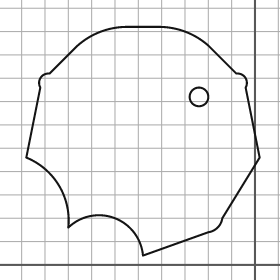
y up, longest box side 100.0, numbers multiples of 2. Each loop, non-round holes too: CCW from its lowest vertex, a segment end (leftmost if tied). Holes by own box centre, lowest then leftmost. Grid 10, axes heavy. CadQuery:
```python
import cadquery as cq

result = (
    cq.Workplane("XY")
    .moveTo(-48.0, 4.0)
    .lineTo(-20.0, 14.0)
    .threePointArc((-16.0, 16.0), (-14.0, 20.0))
    .lineTo(2.0, 46.0)
    .lineTo(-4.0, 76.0)
    .threePointArc((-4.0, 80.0), (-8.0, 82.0))
    .lineTo(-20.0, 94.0)
    .threePointArc((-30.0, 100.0), (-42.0, 102.0))
    .lineTo(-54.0, 102.0)
    .threePointArc((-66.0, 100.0), (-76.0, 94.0))
    .lineTo(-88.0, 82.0)
    .threePointArc((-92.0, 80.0), (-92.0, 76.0))
    .lineTo(-98.0, 46.0)
    .threePointArc((-84.0, 34.0), (-80.0, 16.0))
    .threePointArc((-60.0, 20.0), (-48.0, 4.0))
    .close()
    .moveTo(-24.0, 72.0)
    .circle(4.0)
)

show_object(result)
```